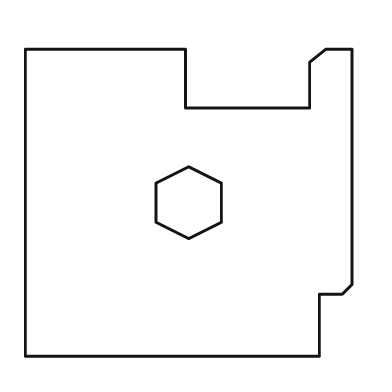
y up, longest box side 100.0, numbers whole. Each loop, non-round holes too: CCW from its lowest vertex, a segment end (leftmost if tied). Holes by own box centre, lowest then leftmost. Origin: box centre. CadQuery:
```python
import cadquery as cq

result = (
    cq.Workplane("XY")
    .moveTo(-50.0, -47.0)
    .lineTo(40.0, -47.0)
    .lineTo(40.0, -28.0)
    .lineTo(47.0, -28.0)
    .lineTo(50.0, -25.0)
    .lineTo(50.0, 47.0)
    .lineTo(42.0, 47.0)
    .lineTo(37.0, 43.0)
    .lineTo(37.0, 29.0)
    .lineTo(-1.0, 29.0)
    .lineTo(-1.0, 47.0)
    .lineTo(-50.0, 47.0)
    .close()
    .moveTo(0.0, -11.0)
    .lineTo(10.0, -6.0)
    .lineTo(10.0, 6.0)
    .lineTo(0.0, 11.0)
    .lineTo(-10.0, 6.0)
    .lineTo(-10.0, -6.0)
    .close()
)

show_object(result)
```